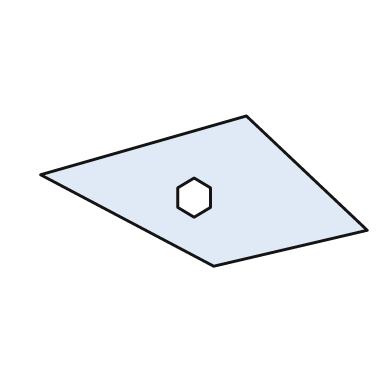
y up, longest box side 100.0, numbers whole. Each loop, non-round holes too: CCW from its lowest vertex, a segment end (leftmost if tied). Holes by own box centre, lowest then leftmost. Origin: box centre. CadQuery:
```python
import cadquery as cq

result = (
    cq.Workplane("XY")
    .moveTo(3.0, -23.0)
    .lineTo(50.0, -12.0)
    .lineTo(13.0, 23.0)
    .lineTo(-50.0, 5.0)
    .close()
    .moveTo(-3.0, -8.0)
    .lineTo(2.0, -5.0)
    .lineTo(2.0, 1.0)
    .lineTo(-3.0, 4.0)
    .lineTo(-8.0, 1.0)
    .lineTo(-8.0, -5.0)
    .close()
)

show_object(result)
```